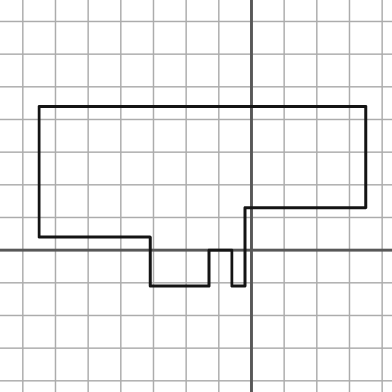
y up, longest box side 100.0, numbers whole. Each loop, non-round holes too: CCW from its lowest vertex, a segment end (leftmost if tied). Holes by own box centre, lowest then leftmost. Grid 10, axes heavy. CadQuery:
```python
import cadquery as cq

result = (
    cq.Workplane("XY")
    .moveTo(-31.0, -11.0)
    .lineTo(-13.0, -11.0)
    .lineTo(-13.0, 0.0)
    .lineTo(-6.0, 0.0)
    .lineTo(-6.0, -11.0)
    .lineTo(-2.0, -11.0)
    .lineTo(-2.0, 13.0)
    .lineTo(35.0, 13.0)
    .lineTo(35.0, 44.0)
    .lineTo(-65.0, 44.0)
    .lineTo(-65.0, 4.0)
    .lineTo(-31.0, 4.0)
    .close()
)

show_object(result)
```